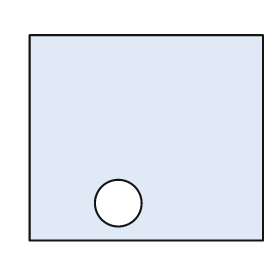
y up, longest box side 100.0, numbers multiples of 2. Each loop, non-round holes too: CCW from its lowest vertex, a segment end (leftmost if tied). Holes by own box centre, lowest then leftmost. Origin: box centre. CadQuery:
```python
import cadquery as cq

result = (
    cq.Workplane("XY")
    .moveTo(-50.0, -44.0)
    .lineTo(50.0, -44.0)
    .lineTo(50.0, 44.0)
    .lineTo(-50.0, 44.0)
    .close()
    .moveTo(-12.0, -28.0)
    .circle(10.0)
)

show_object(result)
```